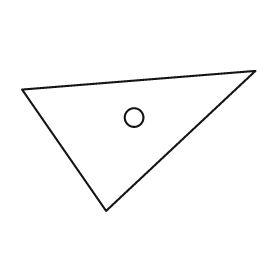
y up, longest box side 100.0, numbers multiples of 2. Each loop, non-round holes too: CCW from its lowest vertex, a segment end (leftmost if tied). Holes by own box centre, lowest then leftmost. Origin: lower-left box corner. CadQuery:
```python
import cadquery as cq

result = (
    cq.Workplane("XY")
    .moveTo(36.0, 0.0)
    .lineTo(100.0, 60.0)
    .lineTo(0.0, 52.0)
    .close()
    .moveTo(48.0, 40.0)
    .circle(4.0)
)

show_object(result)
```